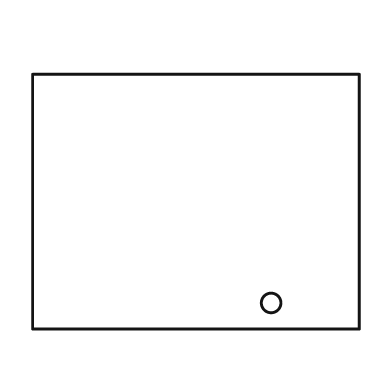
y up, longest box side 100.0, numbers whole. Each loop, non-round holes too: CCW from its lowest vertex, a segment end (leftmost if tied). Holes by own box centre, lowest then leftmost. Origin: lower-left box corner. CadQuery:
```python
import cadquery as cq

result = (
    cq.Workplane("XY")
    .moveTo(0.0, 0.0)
    .lineTo(100.0, 0.0)
    .lineTo(100.0, 78.0)
    .lineTo(0.0, 78.0)
    .close()
    .moveTo(73.0, 8.0)
    .circle(3.0)
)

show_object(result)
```